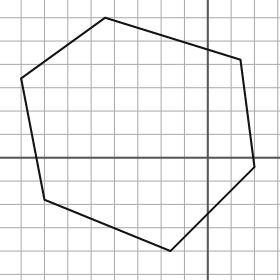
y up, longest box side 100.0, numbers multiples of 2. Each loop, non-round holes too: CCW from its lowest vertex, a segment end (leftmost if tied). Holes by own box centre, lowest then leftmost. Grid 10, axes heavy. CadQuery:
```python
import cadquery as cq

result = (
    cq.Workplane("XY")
    .moveTo(-16.0, -40.0)
    .lineTo(20.0, -4.0)
    .lineTo(14.0, 42.0)
    .lineTo(-44.0, 60.0)
    .lineTo(-80.0, 34.0)
    .lineTo(-70.0, -18.0)
    .close()
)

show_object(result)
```